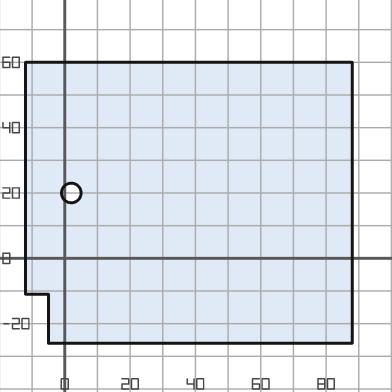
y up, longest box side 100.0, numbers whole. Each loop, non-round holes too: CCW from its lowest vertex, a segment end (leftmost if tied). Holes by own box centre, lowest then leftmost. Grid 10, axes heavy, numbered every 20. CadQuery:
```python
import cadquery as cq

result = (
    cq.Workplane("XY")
    .moveTo(-5.0, -26.0)
    .lineTo(88.0, -26.0)
    .lineTo(88.0, 60.0)
    .lineTo(-12.0, 60.0)
    .lineTo(-12.0, -11.0)
    .lineTo(-5.0, -11.0)
    .close()
    .moveTo(2.0, 20.0)
    .circle(3.0)
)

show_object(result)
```